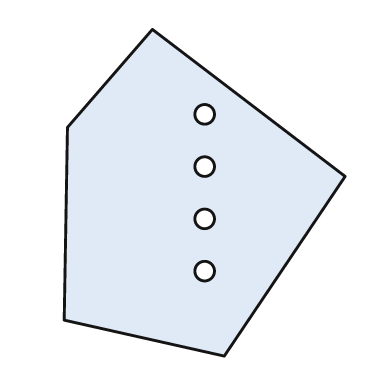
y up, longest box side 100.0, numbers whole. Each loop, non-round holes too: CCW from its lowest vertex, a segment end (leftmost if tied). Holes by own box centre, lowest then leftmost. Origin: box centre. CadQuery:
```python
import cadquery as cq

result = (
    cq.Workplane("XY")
    .moveTo(6.0, -50.0)
    .lineTo(43.0, 5.0)
    .lineTo(-16.0, 50.0)
    .lineTo(-42.0, 20.0)
    .lineTo(-43.0, -39.0)
    .close()
    .moveTo(0.0, -24.0)
    .circle(3.0)
    .moveTo(0.0, -8.0)
    .circle(3.0)
    .moveTo(0.0, 8.0)
    .circle(3.0)
    .moveTo(0.0, 24.0)
    .circle(3.0)
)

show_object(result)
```